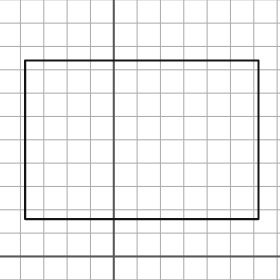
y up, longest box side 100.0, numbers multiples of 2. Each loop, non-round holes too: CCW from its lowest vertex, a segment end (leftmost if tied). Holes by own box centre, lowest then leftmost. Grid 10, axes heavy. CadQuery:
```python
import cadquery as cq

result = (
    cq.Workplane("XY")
    .moveTo(-38.0, 16.0)
    .lineTo(62.0, 16.0)
    .lineTo(62.0, 84.0)
    .lineTo(-38.0, 84.0)
    .close()
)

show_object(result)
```